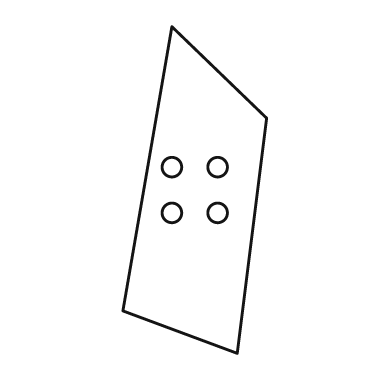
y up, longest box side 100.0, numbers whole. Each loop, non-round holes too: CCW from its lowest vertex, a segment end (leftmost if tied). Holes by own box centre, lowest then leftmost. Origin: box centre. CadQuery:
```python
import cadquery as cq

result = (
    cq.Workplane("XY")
    .moveTo(13.0, -50.0)
    .lineTo(22.0, 22.0)
    .lineTo(-7.0, 50.0)
    .lineTo(-22.0, -37.0)
    .close()
    .moveTo(-7.0, -7.0)
    .circle(3.0)
    .moveTo(7.0, -7.0)
    .circle(3.0)
    .moveTo(-7.0, 7.0)
    .circle(3.0)
    .moveTo(7.0, 7.0)
    .circle(3.0)
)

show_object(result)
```